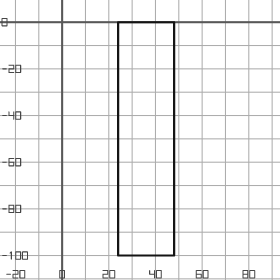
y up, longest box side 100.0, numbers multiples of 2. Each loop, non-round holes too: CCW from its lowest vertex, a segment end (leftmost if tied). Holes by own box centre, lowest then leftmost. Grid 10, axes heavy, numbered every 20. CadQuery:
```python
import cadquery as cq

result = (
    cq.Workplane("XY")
    .moveTo(24.0, -100.0)
    .lineTo(48.0, -100.0)
    .lineTo(48.0, 0.0)
    .lineTo(24.0, 0.0)
    .close()
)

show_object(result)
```